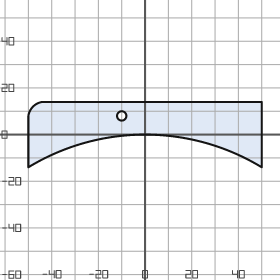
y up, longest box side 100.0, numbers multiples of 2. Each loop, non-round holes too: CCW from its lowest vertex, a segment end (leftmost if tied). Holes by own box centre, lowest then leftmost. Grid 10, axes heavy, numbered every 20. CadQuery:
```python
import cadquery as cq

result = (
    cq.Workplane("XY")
    .moveTo(-50.0, -14.0)
    .threePointArc((0.0, 0.0), (50.0, -14.0))
    .lineTo(50.0, 14.0)
    .lineTo(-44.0, 14.0)
    .threePointArc((-48.0, 12.0), (-50.0, 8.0))
    .close()
    .moveTo(-10.0, 8.0)
    .circle(2.0)
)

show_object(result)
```